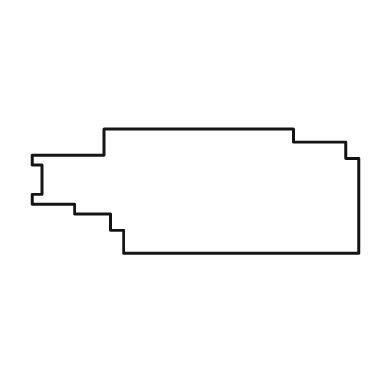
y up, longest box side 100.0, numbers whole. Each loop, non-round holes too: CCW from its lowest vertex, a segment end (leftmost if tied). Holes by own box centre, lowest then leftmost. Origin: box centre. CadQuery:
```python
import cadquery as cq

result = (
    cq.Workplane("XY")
    .moveTo(-22.0, -19.0)
    .lineTo(50.0, -19.0)
    .lineTo(50.0, 10.0)
    .lineTo(46.0, 10.0)
    .lineTo(46.0, 15.0)
    .lineTo(30.0, 15.0)
    .lineTo(30.0, 19.0)
    .lineTo(-28.0, 19.0)
    .lineTo(-28.0, 11.0)
    .lineTo(-50.0, 11.0)
    .lineTo(-50.0, 8.0)
    .lineTo(-47.0, 8.0)
    .lineTo(-47.0, -1.0)
    .lineTo(-50.0, -1.0)
    .lineTo(-50.0, -4.0)
    .lineTo(-37.0, -4.0)
    .lineTo(-37.0, -7.0)
    .lineTo(-26.0, -7.0)
    .lineTo(-26.0, -12.0)
    .lineTo(-22.0, -12.0)
    .close()
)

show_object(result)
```